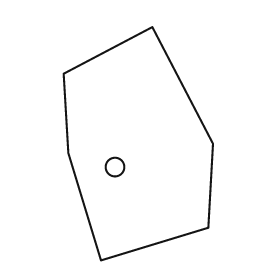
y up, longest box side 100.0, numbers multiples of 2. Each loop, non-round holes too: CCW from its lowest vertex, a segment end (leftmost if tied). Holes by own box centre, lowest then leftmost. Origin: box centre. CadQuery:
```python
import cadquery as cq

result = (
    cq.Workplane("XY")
    .moveTo(-16.0, -50.0)
    .lineTo(30.0, -36.0)
    .lineTo(32.0, 0.0)
    .lineTo(6.0, 50.0)
    .lineTo(-32.0, 30.0)
    .lineTo(-30.0, -4.0)
    .close()
    .moveTo(-10.0, -10.0)
    .circle(4.0)
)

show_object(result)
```